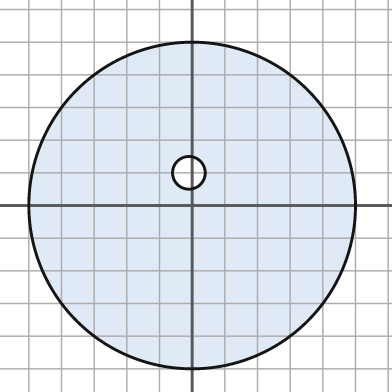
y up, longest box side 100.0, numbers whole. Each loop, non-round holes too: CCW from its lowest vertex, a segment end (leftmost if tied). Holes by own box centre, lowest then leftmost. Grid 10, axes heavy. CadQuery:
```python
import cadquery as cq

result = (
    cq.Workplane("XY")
    .moveTo(0.0, 0.0)
    .circle(50.0)
    .moveTo(-1.0, 10.0)
    .circle(5.0)
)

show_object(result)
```